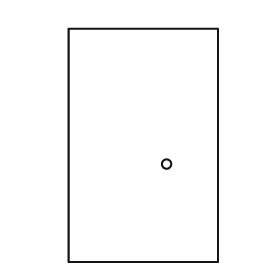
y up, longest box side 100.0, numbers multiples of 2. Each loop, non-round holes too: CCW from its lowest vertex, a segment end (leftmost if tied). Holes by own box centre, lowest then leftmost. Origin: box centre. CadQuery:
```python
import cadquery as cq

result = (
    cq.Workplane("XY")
    .moveTo(-32.0, -50.0)
    .lineTo(32.0, -50.0)
    .lineTo(32.0, 50.0)
    .lineTo(-32.0, 50.0)
    .close()
    .moveTo(10.0, -8.0)
    .circle(2.0)
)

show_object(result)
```